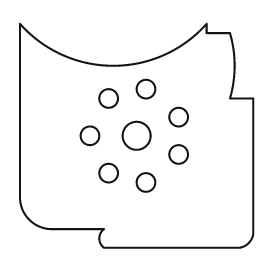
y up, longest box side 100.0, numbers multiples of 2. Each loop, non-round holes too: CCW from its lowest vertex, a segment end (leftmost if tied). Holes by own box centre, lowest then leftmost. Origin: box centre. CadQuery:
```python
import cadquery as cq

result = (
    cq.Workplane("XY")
    .moveTo(-14.0, -48.0)
    .lineTo(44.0, -48.0)
    .threePointArc((48.0, -46.0), (50.0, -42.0))
    .lineTo(50.0, 16.0)
    .lineTo(40.0, 16.0)
    .threePointArc((42.0, 30.0), (40.0, 44.0))
    .lineTo(30.0, 44.0)
    .lineTo(30.0, 48.0)
    .threePointArc((-10.0, 30.0), (-50.0, 48.0))
    .lineTo(-50.0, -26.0)
    .threePointArc((-46.0, -36.0), (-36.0, -40.0))
    .lineTo(-14.0, -40.0)
    .threePointArc((-16.0, -44.0), (-14.0, -48.0))
    .close()
    .moveTo(4.0, -20.0)
    .circle(4.0)
    .moveTo(-12.0, -16.0)
    .circle(4.0)
    .moveTo(18.0, -8.0)
    .circle(4.0)
    .moveTo(-20.0, 0.0)
    .circle(4.0)
    .moveTo(0.0, 0.0)
    .circle(6.0)
    .moveTo(18.0, 8.0)
    .circle(4.0)
    .moveTo(-12.0, 16.0)
    .circle(4.0)
    .moveTo(4.0, 20.0)
    .circle(4.0)
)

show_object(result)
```